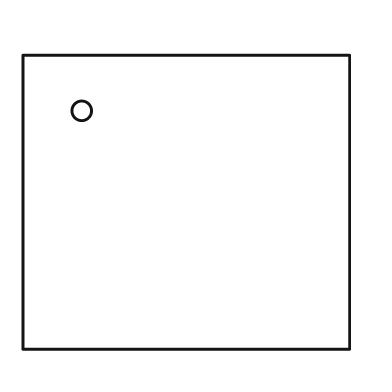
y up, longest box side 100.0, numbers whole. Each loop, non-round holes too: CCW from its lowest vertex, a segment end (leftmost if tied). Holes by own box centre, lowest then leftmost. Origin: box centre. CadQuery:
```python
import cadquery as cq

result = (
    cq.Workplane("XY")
    .moveTo(-50.0, -45.0)
    .lineTo(50.0, -45.0)
    .lineTo(50.0, 45.0)
    .lineTo(-50.0, 45.0)
    .close()
    .moveTo(-32.0, 28.0)
    .circle(3.0)
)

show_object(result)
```